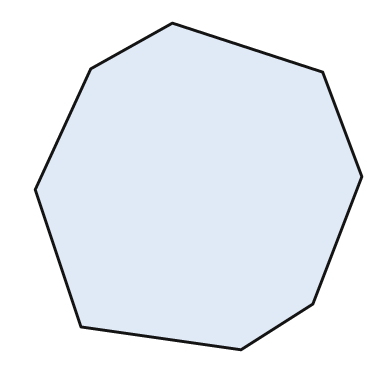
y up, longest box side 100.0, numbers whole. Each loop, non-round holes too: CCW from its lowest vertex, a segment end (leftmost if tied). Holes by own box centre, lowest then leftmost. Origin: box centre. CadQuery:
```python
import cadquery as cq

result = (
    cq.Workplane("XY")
    .moveTo(13.0, -50.0)
    .lineTo(35.0, -36.0)
    .lineTo(50.0, 3.0)
    .lineTo(38.0, 35.0)
    .lineTo(-8.0, 50.0)
    .lineTo(-33.0, 36.0)
    .lineTo(-50.0, -1.0)
    .lineTo(-36.0, -43.0)
    .close()
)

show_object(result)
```